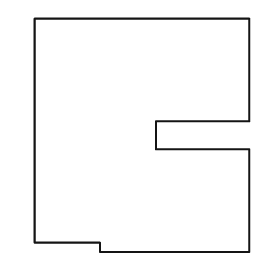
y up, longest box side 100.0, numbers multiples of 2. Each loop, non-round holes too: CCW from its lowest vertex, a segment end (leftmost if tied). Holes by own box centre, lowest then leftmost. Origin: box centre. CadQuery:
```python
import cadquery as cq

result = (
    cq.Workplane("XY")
    .moveTo(-18.0, -50.0)
    .lineTo(46.0, -50.0)
    .lineTo(46.0, -6.0)
    .lineTo(6.0, -6.0)
    .lineTo(6.0, 6.0)
    .lineTo(46.0, 6.0)
    .lineTo(46.0, 50.0)
    .lineTo(-46.0, 50.0)
    .lineTo(-46.0, -46.0)
    .lineTo(-18.0, -46.0)
    .close()
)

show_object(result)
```